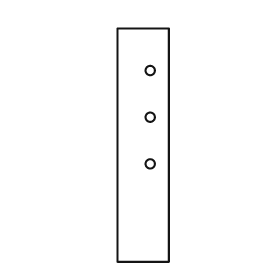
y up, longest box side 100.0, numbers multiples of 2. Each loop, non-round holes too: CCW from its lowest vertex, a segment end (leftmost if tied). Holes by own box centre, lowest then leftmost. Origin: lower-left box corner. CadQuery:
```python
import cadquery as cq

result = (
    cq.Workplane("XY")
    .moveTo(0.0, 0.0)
    .lineTo(22.0, 0.0)
    .lineTo(22.0, 100.0)
    .lineTo(0.0, 100.0)
    .close()
    .moveTo(14.0, 42.0)
    .circle(2.0)
    .moveTo(14.0, 62.0)
    .circle(2.0)
    .moveTo(14.0, 82.0)
    .circle(2.0)
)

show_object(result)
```